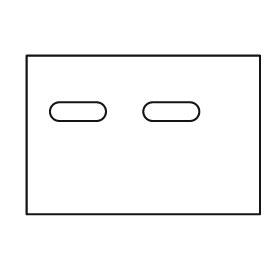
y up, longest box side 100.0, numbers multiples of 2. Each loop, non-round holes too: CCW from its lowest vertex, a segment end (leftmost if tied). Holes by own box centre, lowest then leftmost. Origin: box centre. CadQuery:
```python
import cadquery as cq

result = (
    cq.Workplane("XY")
    .moveTo(-50.0, -34.0)
    .lineTo(50.0, -34.0)
    .lineTo(50.0, 34.0)
    .lineTo(-50.0, 34.0)
    .close()
    .moveTo(-36.0, 6.0)
    .lineTo(-20.0, 6.0)
    .threePointArc((-16.0, 10.0), (-20.0, 14.0))
    .lineTo(-36.0, 14.0)
    .threePointArc((-40.0, 10.0), (-36.0, 6.0))
    .close()
    .moveTo(4.0, 6.0)
    .lineTo(20.0, 6.0)
    .threePointArc((24.0, 10.0), (20.0, 14.0))
    .lineTo(4.0, 14.0)
    .threePointArc((0.0, 10.0), (4.0, 6.0))
    .close()
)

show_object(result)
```